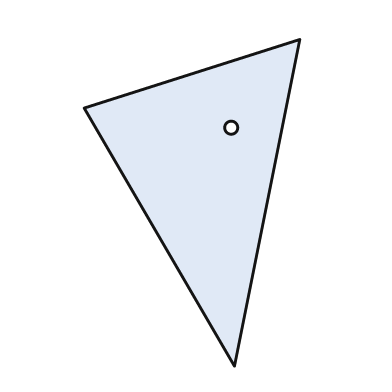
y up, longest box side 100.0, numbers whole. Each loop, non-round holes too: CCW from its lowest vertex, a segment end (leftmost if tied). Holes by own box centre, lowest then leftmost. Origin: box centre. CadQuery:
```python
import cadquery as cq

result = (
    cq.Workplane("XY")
    .moveTo(13.0, -50.0)
    .lineTo(33.0, 50.0)
    .lineTo(-33.0, 29.0)
    .close()
    .moveTo(12.0, 23.0)
    .circle(2.0)
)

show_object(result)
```